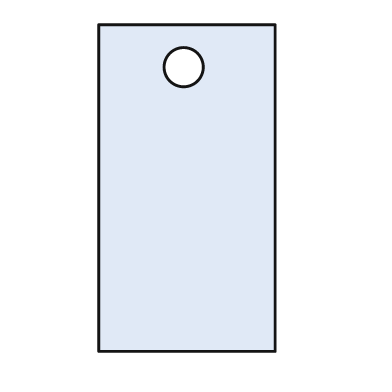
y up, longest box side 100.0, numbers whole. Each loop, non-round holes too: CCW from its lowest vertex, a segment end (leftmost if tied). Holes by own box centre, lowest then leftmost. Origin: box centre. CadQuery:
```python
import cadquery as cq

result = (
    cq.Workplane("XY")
    .moveTo(-27.0, -50.0)
    .lineTo(27.0, -50.0)
    .lineTo(27.0, 50.0)
    .lineTo(-27.0, 50.0)
    .close()
    .moveTo(-1.0, 37.0)
    .circle(6.0)
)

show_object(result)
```